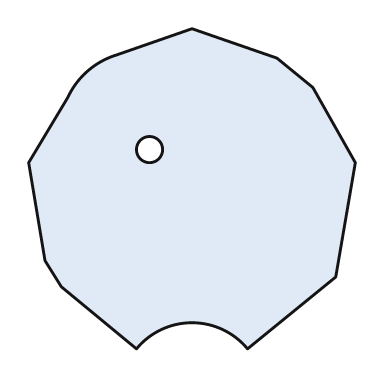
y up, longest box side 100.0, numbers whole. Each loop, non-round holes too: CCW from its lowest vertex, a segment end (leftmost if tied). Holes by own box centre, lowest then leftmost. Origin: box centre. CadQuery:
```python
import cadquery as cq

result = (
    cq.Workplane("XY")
    .moveTo(-17.0, -49.0)
    .threePointArc((0.0, -41.0), (17.0, -49.0))
    .lineTo(44.0, -27.0)
    .lineTo(50.0, 8.0)
    .lineTo(37.0, 31.0)
    .lineTo(26.0, 40.0)
    .lineTo(0.0, 49.0)
    .lineTo(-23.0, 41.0)
    .threePointArc((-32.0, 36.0), (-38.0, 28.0))
    .lineTo(-50.0, 8.0)
    .lineTo(-45.0, -22.0)
    .lineTo(-40.0, -30.0)
    .close()
    .moveTo(-13.0, 12.0)
    .circle(4.0)
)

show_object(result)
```